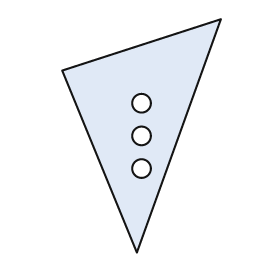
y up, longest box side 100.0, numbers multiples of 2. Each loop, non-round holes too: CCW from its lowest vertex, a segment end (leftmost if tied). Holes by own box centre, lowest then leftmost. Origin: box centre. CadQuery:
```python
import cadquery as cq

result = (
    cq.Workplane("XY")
    .moveTo(-2.0, -50.0)
    .lineTo(34.0, 50.0)
    .lineTo(-34.0, 28.0)
    .close()
    .moveTo(0.0, -14.0)
    .circle(4.0)
    .moveTo(0.0, 0.0)
    .circle(4.0)
    .moveTo(0.0, 14.0)
    .circle(4.0)
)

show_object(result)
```